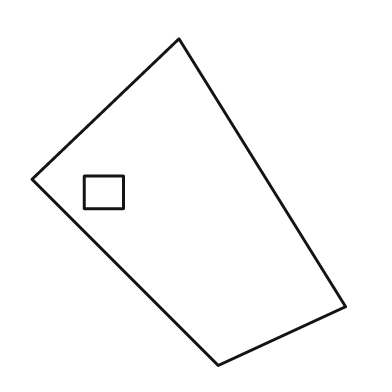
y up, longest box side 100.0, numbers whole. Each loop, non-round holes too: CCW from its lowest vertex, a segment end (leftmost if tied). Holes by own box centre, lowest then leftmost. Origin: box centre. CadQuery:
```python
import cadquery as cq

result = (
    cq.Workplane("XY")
    .moveTo(9.0, -50.0)
    .lineTo(48.0, -32.0)
    .lineTo(-3.0, 50.0)
    .lineTo(-48.0, 7.0)
    .close()
    .moveTo(-32.0, -2.0)
    .lineTo(-20.0, -2.0)
    .lineTo(-20.0, 8.0)
    .lineTo(-32.0, 8.0)
    .close()
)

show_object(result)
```